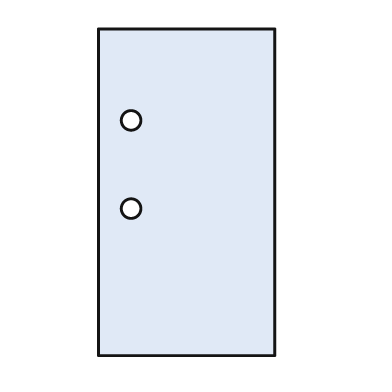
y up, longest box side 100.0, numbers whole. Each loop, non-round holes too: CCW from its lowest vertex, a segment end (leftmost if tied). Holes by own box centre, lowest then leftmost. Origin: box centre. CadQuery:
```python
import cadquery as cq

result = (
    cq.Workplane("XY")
    .moveTo(-27.0, -50.0)
    .lineTo(27.0, -50.0)
    .lineTo(27.0, 50.0)
    .lineTo(-27.0, 50.0)
    .close()
    .moveTo(-17.0, -5.0)
    .circle(3.0)
    .moveTo(-17.0, 22.0)
    .circle(3.0)
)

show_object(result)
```